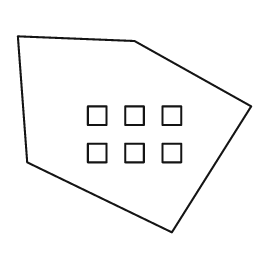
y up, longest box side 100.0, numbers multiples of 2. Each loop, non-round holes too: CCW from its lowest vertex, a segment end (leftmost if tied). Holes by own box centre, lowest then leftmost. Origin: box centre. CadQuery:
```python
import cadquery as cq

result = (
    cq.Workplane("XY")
    .moveTo(16.0, -42.0)
    .lineTo(50.0, 12.0)
    .lineTo(0.0, 40.0)
    .lineTo(-50.0, 42.0)
    .lineTo(-46.0, -12.0)
    .close()
    .moveTo(-20.0, -12.0)
    .lineTo(-12.0, -12.0)
    .lineTo(-12.0, -4.0)
    .lineTo(-20.0, -4.0)
    .close()
    .moveTo(-4.0, -12.0)
    .lineTo(4.0, -12.0)
    .lineTo(4.0, -4.0)
    .lineTo(-4.0, -4.0)
    .close()
    .moveTo(12.0, -12.0)
    .lineTo(20.0, -12.0)
    .lineTo(20.0, -4.0)
    .lineTo(12.0, -4.0)
    .close()
    .moveTo(-20.0, 4.0)
    .lineTo(-12.0, 4.0)
    .lineTo(-12.0, 12.0)
    .lineTo(-20.0, 12.0)
    .close()
    .moveTo(-4.0, 4.0)
    .lineTo(4.0, 4.0)
    .lineTo(4.0, 12.0)
    .lineTo(-4.0, 12.0)
    .close()
    .moveTo(12.0, 4.0)
    .lineTo(20.0, 4.0)
    .lineTo(20.0, 12.0)
    .lineTo(12.0, 12.0)
    .close()
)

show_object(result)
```